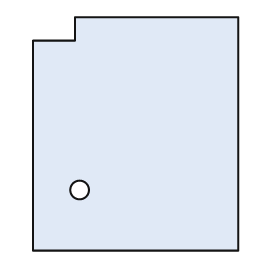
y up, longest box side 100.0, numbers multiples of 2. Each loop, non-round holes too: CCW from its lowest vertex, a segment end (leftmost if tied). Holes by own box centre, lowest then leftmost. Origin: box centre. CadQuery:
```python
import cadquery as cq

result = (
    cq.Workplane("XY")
    .moveTo(-44.0, -50.0)
    .lineTo(44.0, -50.0)
    .lineTo(44.0, 50.0)
    .lineTo(-26.0, 50.0)
    .lineTo(-26.0, 40.0)
    .lineTo(-44.0, 40.0)
    .close()
    .moveTo(-24.0, -24.0)
    .circle(4.0)
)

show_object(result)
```